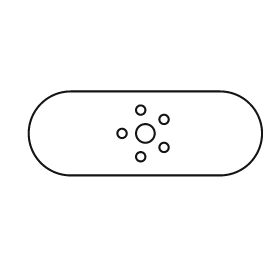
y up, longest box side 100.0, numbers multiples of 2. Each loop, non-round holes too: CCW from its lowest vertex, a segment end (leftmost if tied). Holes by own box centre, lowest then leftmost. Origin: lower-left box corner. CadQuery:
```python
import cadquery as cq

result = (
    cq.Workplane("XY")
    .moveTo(18.0, 0.0)
    .lineTo(82.0, 0.0)
    .threePointArc((100.0, 18.0), (82.0, 36.0))
    .lineTo(18.0, 36.0)
    .threePointArc((0.0, 18.0), (18.0, 0.0))
    .close()
    .moveTo(48.0, 8.0)
    .circle(2.0)
    .moveTo(58.0, 12.0)
    .circle(2.0)
    .moveTo(40.0, 18.0)
    .circle(2.0)
    .moveTo(50.0, 18.0)
    .circle(4.0)
    .moveTo(58.0, 24.0)
    .circle(2.0)
    .moveTo(48.0, 28.0)
    .circle(2.0)
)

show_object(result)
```